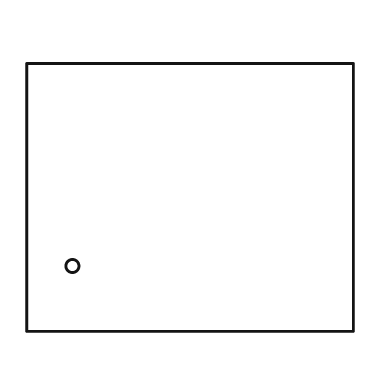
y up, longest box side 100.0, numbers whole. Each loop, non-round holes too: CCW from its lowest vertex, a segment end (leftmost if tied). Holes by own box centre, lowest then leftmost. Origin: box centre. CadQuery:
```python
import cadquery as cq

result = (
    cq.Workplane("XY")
    .moveTo(-50.0, -41.0)
    .lineTo(50.0, -41.0)
    .lineTo(50.0, 41.0)
    .lineTo(-50.0, 41.0)
    .close()
    .moveTo(-36.0, -21.0)
    .circle(2.0)
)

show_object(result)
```